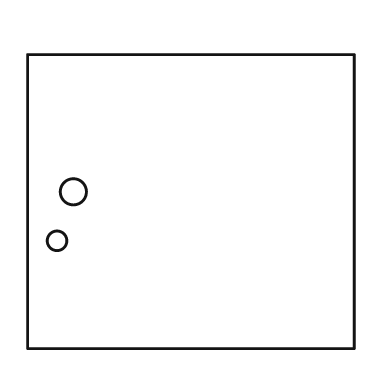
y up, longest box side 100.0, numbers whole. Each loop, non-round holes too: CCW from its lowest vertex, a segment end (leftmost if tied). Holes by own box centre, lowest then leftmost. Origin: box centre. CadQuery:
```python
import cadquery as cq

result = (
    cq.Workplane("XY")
    .moveTo(-50.0, -45.0)
    .lineTo(50.0, -45.0)
    .lineTo(50.0, 45.0)
    .lineTo(-50.0, 45.0)
    .close()
    .moveTo(-41.0, -12.0)
    .circle(3.0)
    .moveTo(-36.0, 3.0)
    .circle(4.0)
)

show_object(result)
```